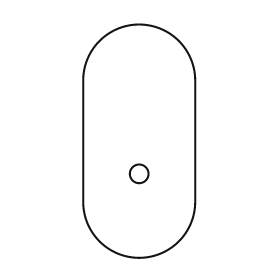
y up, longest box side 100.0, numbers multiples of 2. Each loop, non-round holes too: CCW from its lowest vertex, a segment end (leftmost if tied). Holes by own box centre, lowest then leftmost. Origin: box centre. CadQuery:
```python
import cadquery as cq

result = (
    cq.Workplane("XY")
    .moveTo(-24.0, -26.0)
    .threePointArc((0.0, -50.0), (24.0, -26.0))
    .lineTo(24.0, 26.0)
    .threePointArc((0.0, 50.0), (-24.0, 26.0))
    .close()
    .moveTo(0.0, -14.0)
    .circle(4.0)
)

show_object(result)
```